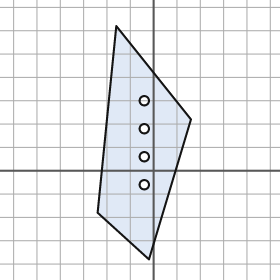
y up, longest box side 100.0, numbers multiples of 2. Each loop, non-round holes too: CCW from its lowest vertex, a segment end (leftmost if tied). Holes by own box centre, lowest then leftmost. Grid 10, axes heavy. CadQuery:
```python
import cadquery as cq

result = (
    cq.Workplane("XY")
    .moveTo(-2.0, -38.0)
    .lineTo(16.0, 22.0)
    .lineTo(-16.0, 62.0)
    .lineTo(-24.0, -18.0)
    .close()
    .moveTo(-4.0, -6.0)
    .circle(2.0)
    .moveTo(-4.0, 6.0)
    .circle(2.0)
    .moveTo(-4.0, 18.0)
    .circle(2.0)
    .moveTo(-4.0, 30.0)
    .circle(2.0)
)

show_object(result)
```